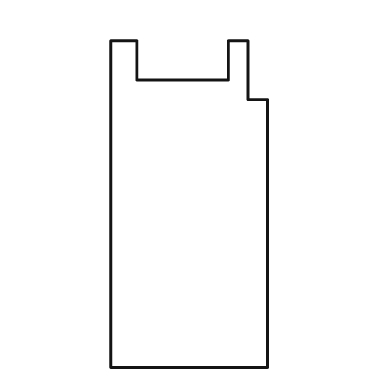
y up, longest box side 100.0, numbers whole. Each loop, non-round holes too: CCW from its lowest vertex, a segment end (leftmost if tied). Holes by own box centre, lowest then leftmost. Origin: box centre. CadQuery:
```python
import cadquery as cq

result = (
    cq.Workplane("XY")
    .moveTo(-24.0, -50.0)
    .lineTo(24.0, -50.0)
    .lineTo(24.0, 32.0)
    .lineTo(18.0, 32.0)
    .lineTo(18.0, 50.0)
    .lineTo(12.0, 50.0)
    .lineTo(12.0, 38.0)
    .lineTo(-16.0, 38.0)
    .lineTo(-16.0, 50.0)
    .lineTo(-24.0, 50.0)
    .close()
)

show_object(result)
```